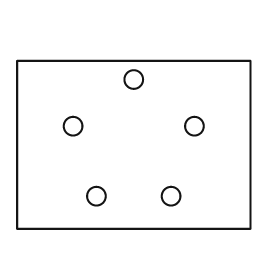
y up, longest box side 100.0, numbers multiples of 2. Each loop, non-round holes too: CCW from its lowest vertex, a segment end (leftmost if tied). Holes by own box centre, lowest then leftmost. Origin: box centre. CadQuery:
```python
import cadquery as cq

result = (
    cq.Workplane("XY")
    .moveTo(-50.0, -36.0)
    .lineTo(50.0, -36.0)
    .lineTo(50.0, 36.0)
    .lineTo(-50.0, 36.0)
    .close()
    .moveTo(-16.0, -22.0)
    .circle(4.0)
    .moveTo(16.0, -22.0)
    .circle(4.0)
    .moveTo(-26.0, 8.0)
    .circle(4.0)
    .moveTo(26.0, 8.0)
    .circle(4.0)
    .moveTo(0.0, 28.0)
    .circle(4.0)
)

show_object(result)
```